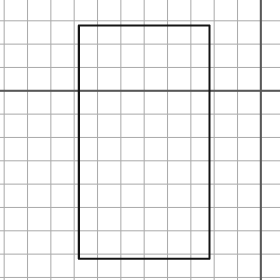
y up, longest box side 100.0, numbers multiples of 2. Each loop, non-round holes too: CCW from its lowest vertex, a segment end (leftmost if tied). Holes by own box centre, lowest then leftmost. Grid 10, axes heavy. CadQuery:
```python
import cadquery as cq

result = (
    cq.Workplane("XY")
    .moveTo(-78.0, -72.0)
    .lineTo(-22.0, -72.0)
    .lineTo(-22.0, 28.0)
    .lineTo(-78.0, 28.0)
    .close()
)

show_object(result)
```